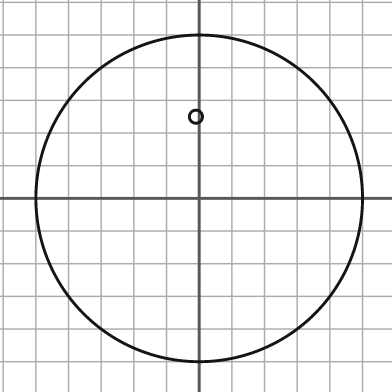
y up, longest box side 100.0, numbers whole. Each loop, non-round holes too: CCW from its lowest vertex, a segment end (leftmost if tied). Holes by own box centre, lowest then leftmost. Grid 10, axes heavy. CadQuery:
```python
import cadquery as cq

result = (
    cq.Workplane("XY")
    .moveTo(0.0, 0.0)
    .circle(50.0)
    .moveTo(-1.0, 25.0)
    .circle(2.0)
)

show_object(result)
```